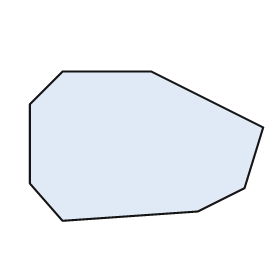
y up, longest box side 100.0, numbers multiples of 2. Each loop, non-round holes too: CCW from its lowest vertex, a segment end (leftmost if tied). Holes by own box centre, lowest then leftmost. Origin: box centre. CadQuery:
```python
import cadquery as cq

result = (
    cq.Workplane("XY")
    .moveTo(-36.0, -32.0)
    .lineTo(22.0, -28.0)
    .lineTo(42.0, -18.0)
    .lineTo(50.0, 8.0)
    .lineTo(2.0, 32.0)
    .lineTo(-36.0, 32.0)
    .lineTo(-50.0, 18.0)
    .lineTo(-50.0, -16.0)
    .close()
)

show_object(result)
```